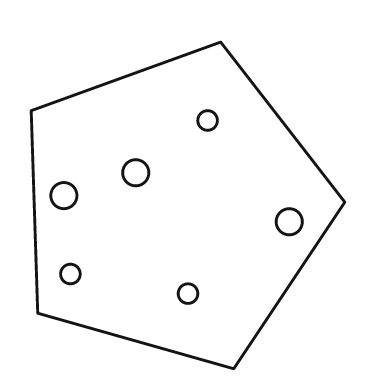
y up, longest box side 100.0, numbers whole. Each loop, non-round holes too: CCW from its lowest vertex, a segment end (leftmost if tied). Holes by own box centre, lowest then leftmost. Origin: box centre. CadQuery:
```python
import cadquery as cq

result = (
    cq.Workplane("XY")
    .moveTo(14.0, -50.0)
    .lineTo(48.0, 1.0)
    .lineTo(10.0, 50.0)
    .lineTo(-48.0, 29.0)
    .lineTo(-46.0, -33.0)
    .close()
    .moveTo(0.0, -27.0)
    .circle(3.0)
    .moveTo(-36.0, -21.0)
    .circle(3.0)
    .moveTo(31.0, -5.0)
    .circle(4.0)
    .moveTo(-38.0, 3.0)
    .circle(4.0)
    .moveTo(-16.0, 10.0)
    .circle(4.0)
    .moveTo(6.0, 26.0)
    .circle(3.0)
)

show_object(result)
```